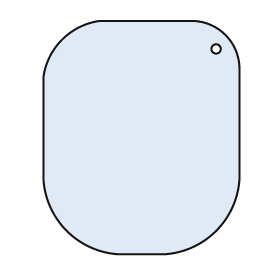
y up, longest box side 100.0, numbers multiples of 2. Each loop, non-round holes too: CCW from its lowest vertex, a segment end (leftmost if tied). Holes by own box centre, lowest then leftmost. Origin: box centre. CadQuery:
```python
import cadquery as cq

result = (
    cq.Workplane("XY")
    .moveTo(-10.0, -50.0)
    .lineTo(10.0, -50.0)
    .threePointArc((32.0, -40.0), (42.0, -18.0))
    .lineTo(42.0, 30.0)
    .threePointArc((36.0, 44.0), (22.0, 50.0))
    .lineTo(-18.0, 50.0)
    .threePointArc((-34.0, 42.0), (-42.0, 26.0))
    .lineTo(-42.0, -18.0)
    .threePointArc((-32.0, -40.0), (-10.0, -50.0))
    .close()
    .moveTo(32.0, 38.0)
    .circle(2.0)
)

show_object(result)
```